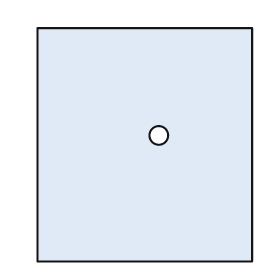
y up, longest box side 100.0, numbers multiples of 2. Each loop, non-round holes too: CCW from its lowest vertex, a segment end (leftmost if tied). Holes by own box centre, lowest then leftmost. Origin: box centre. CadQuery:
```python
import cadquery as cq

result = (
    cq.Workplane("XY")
    .moveTo(-46.0, -50.0)
    .lineTo(46.0, -50.0)
    .lineTo(46.0, 50.0)
    .lineTo(-46.0, 50.0)
    .close()
    .moveTo(6.0, 4.0)
    .circle(4.0)
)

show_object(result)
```